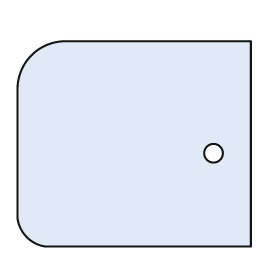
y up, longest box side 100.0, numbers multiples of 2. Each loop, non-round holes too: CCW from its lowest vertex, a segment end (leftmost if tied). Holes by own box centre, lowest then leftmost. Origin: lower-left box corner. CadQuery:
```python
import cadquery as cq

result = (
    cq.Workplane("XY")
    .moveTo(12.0, 0.0)
    .lineTo(100.0, 0.0)
    .lineTo(100.0, 88.0)
    .lineTo(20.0, 88.0)
    .threePointArc((6.0, 82.0), (0.0, 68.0))
    .lineTo(0.0, 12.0)
    .threePointArc((4.0, 4.0), (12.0, 0.0))
    .close()
    .moveTo(84.0, 40.0)
    .circle(4.0)
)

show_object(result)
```